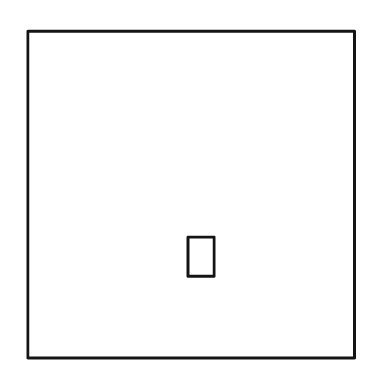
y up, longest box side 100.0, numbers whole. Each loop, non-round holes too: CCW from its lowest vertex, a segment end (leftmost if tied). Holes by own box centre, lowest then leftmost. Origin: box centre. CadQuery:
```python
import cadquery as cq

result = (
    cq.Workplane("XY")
    .moveTo(-50.0, -50.0)
    .lineTo(50.0, -50.0)
    .lineTo(50.0, 50.0)
    .lineTo(-50.0, 50.0)
    .close()
    .moveTo(-1.0, -25.0)
    .lineTo(7.0, -25.0)
    .lineTo(7.0, -13.0)
    .lineTo(-1.0, -13.0)
    .close()
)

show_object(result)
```